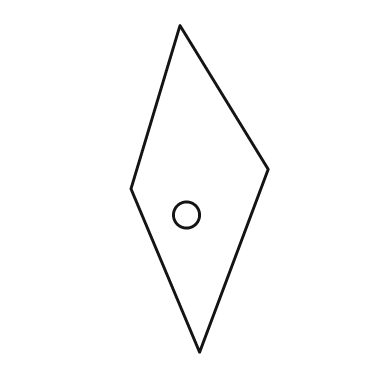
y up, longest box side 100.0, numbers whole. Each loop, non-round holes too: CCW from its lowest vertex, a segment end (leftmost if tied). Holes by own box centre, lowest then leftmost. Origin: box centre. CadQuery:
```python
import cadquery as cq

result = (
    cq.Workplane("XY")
    .moveTo(0.0, -50.0)
    .lineTo(21.0, 6.0)
    .lineTo(-6.0, 50.0)
    .lineTo(-21.0, 0.0)
    .close()
    .moveTo(-4.0, -8.0)
    .circle(4.0)
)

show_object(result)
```